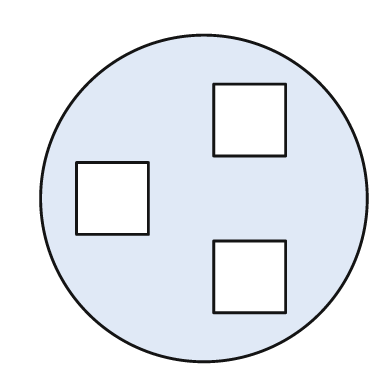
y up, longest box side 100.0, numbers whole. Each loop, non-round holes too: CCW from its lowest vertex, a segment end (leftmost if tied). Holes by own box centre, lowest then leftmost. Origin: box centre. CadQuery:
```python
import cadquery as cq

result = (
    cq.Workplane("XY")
    .moveTo(0.0, 0.0)
    .circle(50.0)
    .moveTo(3.0, -35.0)
    .lineTo(25.0, -35.0)
    .lineTo(25.0, -13.0)
    .lineTo(3.0, -13.0)
    .close()
    .moveTo(-39.0, -11.0)
    .lineTo(-17.0, -11.0)
    .lineTo(-17.0, 11.0)
    .lineTo(-39.0, 11.0)
    .close()
    .moveTo(3.0, 13.0)
    .lineTo(25.0, 13.0)
    .lineTo(25.0, 35.0)
    .lineTo(3.0, 35.0)
    .close()
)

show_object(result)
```